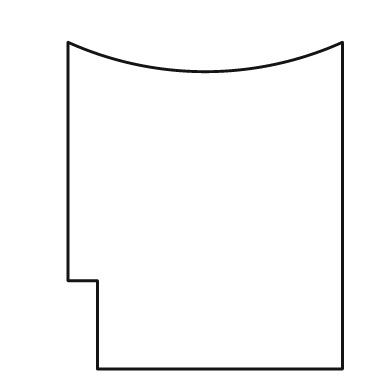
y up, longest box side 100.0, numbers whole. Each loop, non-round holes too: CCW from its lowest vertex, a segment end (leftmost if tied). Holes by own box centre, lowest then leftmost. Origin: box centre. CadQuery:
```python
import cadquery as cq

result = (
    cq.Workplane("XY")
    .moveTo(-33.0, -50.0)
    .lineTo(42.0, -50.0)
    .lineTo(42.0, 50.0)
    .threePointArc((0.0, 41.0), (-42.0, 50.0))
    .lineTo(-42.0, -23.0)
    .lineTo(-33.0, -23.0)
    .close()
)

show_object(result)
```